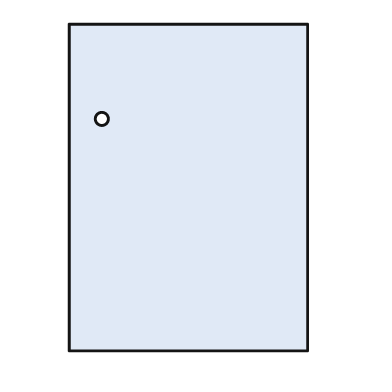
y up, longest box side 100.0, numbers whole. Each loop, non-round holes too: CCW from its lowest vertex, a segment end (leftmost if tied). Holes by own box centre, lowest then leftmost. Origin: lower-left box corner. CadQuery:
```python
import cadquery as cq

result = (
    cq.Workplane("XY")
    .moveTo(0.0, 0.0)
    .lineTo(73.0, 0.0)
    .lineTo(73.0, 100.0)
    .lineTo(0.0, 100.0)
    .close()
    .moveTo(10.0, 71.0)
    .circle(2.0)
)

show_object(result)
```